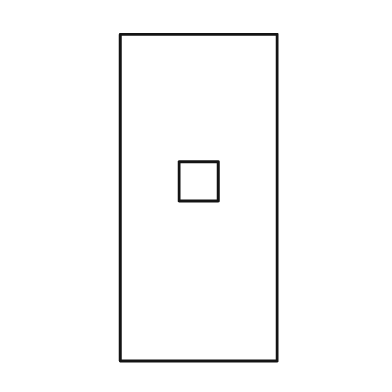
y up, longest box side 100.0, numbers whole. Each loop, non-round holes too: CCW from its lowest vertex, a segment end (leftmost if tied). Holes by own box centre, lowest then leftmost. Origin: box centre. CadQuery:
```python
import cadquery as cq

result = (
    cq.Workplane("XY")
    .moveTo(-24.0, -50.0)
    .lineTo(24.0, -50.0)
    .lineTo(24.0, 50.0)
    .lineTo(-24.0, 50.0)
    .close()
    .moveTo(-6.0, -1.0)
    .lineTo(6.0, -1.0)
    .lineTo(6.0, 11.0)
    .lineTo(-6.0, 11.0)
    .close()
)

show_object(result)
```